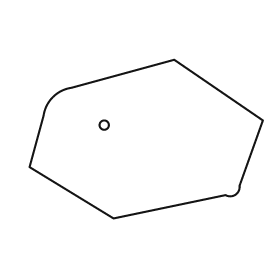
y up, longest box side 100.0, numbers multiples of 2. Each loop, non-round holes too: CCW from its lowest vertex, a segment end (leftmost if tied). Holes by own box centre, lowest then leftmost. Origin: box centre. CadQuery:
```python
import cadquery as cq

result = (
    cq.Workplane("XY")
    .moveTo(-14.0, -34.0)
    .lineTo(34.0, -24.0)
    .threePointArc((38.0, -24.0), (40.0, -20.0))
    .lineTo(50.0, 8.0)
    .lineTo(12.0, 34.0)
    .lineTo(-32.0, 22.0)
    .threePointArc((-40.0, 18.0), (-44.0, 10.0))
    .lineTo(-50.0, -12.0)
    .close()
    .moveTo(-18.0, 6.0)
    .circle(2.0)
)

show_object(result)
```